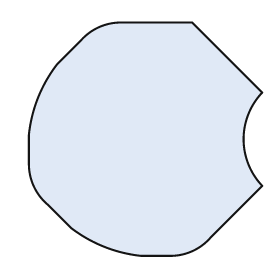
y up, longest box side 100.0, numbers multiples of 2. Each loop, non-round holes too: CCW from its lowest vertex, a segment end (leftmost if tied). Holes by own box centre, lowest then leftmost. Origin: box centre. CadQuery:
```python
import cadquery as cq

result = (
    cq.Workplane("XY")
    .moveTo(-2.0, -50.0)
    .lineTo(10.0, -50.0)
    .threePointArc((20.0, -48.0), (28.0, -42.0))
    .lineTo(50.0, -20.0)
    .threePointArc((42.0, 0.0), (50.0, 20.0))
    .lineTo(20.0, 50.0)
    .lineTo(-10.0, 50.0)
    .threePointArc((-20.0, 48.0), (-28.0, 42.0))
    .lineTo(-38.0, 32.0)
    .threePointArc((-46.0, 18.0), (-50.0, 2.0))
    .lineTo(-50.0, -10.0)
    .threePointArc((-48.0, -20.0), (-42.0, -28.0))
    .lineTo(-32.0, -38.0)
    .threePointArc((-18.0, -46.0), (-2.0, -50.0))
    .close()
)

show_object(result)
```